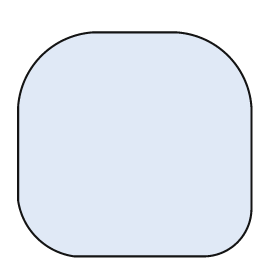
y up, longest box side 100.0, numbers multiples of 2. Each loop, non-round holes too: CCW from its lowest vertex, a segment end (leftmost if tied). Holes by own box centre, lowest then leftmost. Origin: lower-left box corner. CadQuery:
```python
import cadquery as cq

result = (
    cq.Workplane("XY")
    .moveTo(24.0, 0.0)
    .lineTo(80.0, 0.0)
    .threePointArc((94.0, 6.0), (100.0, 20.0))
    .lineTo(100.0, 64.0)
    .threePointArc((90.0, 86.0), (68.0, 96.0))
    .lineTo(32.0, 96.0)
    .threePointArc((10.0, 86.0), (0.0, 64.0))
    .lineTo(0.0, 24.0)
    .threePointArc((8.0, 8.0), (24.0, 0.0))
    .close()
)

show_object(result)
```